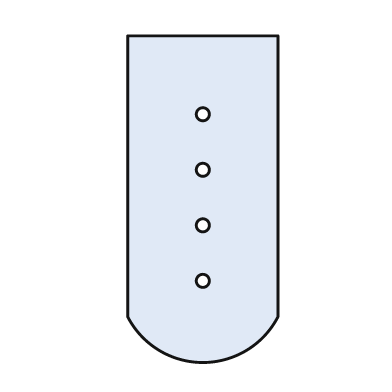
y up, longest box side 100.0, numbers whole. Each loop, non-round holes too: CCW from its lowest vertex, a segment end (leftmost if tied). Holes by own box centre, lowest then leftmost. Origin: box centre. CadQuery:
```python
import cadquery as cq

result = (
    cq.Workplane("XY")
    .moveTo(-23.0, -36.0)
    .threePointArc((0.0, -50.0), (23.0, -36.0))
    .lineTo(23.0, 50.0)
    .lineTo(-23.0, 50.0)
    .close()
    .moveTo(0.0, -25.0)
    .circle(2.0)
    .moveTo(0.0, -8.0)
    .circle(2.0)
    .moveTo(0.0, 9.0)
    .circle(2.0)
    .moveTo(0.0, 26.0)
    .circle(2.0)
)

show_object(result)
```